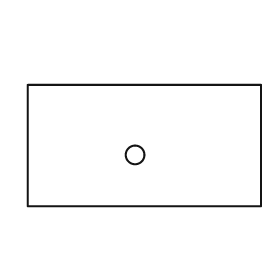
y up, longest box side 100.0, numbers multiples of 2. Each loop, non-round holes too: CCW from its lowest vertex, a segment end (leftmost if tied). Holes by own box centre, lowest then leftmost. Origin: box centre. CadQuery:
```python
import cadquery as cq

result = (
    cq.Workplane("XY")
    .moveTo(-50.0, -26.0)
    .lineTo(50.0, -26.0)
    .lineTo(50.0, 26.0)
    .lineTo(-50.0, 26.0)
    .close()
    .moveTo(-4.0, -4.0)
    .circle(4.0)
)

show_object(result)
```